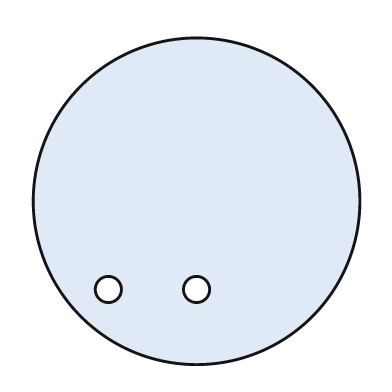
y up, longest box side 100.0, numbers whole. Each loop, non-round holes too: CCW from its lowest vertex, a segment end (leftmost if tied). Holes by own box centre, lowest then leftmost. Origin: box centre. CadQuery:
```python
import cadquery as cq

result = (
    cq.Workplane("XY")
    .moveTo(0.0, 0.0)
    .circle(50.0)
    .moveTo(-27.0, -27.0)
    .circle(4.0)
    .moveTo(0.0, -27.0)
    .circle(4.0)
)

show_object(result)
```